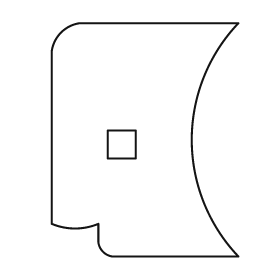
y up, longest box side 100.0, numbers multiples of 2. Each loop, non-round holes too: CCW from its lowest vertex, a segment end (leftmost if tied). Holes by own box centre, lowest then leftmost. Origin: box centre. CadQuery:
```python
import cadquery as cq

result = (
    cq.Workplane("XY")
    .moveTo(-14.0, -50.0)
    .lineTo(40.0, -50.0)
    .threePointArc((20.0, 0.0), (40.0, 50.0))
    .lineTo(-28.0, 50.0)
    .threePointArc((-36.0, 46.0), (-40.0, 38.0))
    .lineTo(-40.0, -36.0)
    .threePointArc((-30.0, -38.0), (-20.0, -36.0))
    .lineTo(-20.0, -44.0)
    .threePointArc((-18.0, -48.0), (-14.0, -50.0))
    .close()
    .moveTo(-16.0, -8.0)
    .lineTo(-4.0, -8.0)
    .lineTo(-4.0, 4.0)
    .lineTo(-16.0, 4.0)
    .close()
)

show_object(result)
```